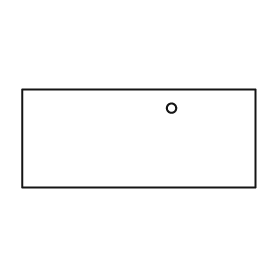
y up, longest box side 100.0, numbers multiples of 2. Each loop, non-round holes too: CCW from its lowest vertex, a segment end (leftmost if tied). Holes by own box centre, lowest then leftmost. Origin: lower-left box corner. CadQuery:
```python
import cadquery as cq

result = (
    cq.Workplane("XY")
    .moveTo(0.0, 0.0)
    .lineTo(100.0, 0.0)
    .lineTo(100.0, 42.0)
    .lineTo(0.0, 42.0)
    .close()
    .moveTo(64.0, 34.0)
    .circle(2.0)
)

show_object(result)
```